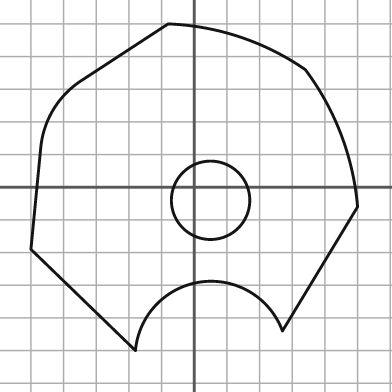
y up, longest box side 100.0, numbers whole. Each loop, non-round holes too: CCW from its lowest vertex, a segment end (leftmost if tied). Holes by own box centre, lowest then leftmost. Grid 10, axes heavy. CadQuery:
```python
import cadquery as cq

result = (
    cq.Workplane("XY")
    .moveTo(-18.0, -50.0)
    .threePointArc((2.0, -29.0), (27.0, -44.0))
    .lineTo(50.0, -6.0)
    .threePointArc((45.0, 16.0), (34.0, 36.0))
    .threePointArc((14.0, 46.0), (-8.0, 50.0))
    .lineTo(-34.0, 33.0)
    .threePointArc((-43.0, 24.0), (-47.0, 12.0))
    .lineTo(-50.0, -19.0)
    .close()
    .moveTo(5.0, -4.0)
    .circle(12.0)
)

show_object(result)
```